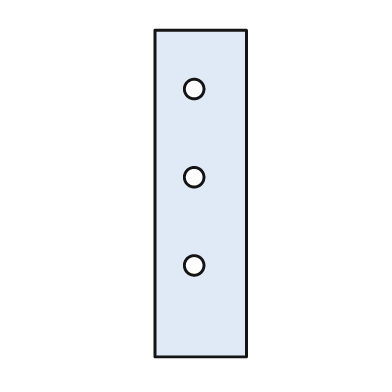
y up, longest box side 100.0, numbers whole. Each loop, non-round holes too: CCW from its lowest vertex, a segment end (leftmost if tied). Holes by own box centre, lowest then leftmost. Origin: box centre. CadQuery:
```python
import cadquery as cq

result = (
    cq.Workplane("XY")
    .moveTo(-14.0, -50.0)
    .lineTo(14.0, -50.0)
    .lineTo(14.0, 50.0)
    .lineTo(-14.0, 50.0)
    .close()
    .moveTo(-2.0, -22.0)
    .circle(3.0)
    .moveTo(-2.0, 5.0)
    .circle(3.0)
    .moveTo(-2.0, 32.0)
    .circle(3.0)
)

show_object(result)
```